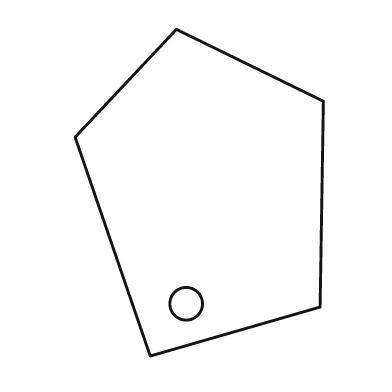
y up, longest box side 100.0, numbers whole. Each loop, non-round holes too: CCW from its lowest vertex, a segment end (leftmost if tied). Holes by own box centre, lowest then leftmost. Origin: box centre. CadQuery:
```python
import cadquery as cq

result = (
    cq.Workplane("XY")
    .moveTo(-15.0, -50.0)
    .lineTo(37.0, -35.0)
    .lineTo(38.0, 28.0)
    .lineTo(-7.0, 50.0)
    .lineTo(-38.0, 17.0)
    .close()
    .moveTo(-4.0, -34.0)
    .circle(5.0)
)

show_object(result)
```